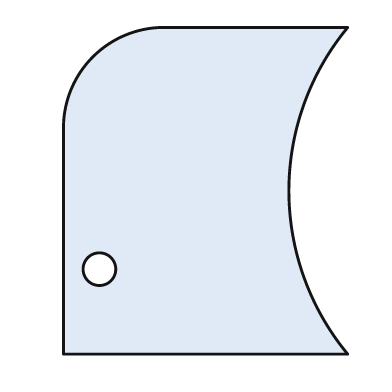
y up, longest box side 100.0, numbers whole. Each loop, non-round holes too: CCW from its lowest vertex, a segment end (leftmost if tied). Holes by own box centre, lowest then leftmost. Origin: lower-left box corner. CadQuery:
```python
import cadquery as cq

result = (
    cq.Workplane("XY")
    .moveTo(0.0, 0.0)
    .lineTo(87.0, 0.0)
    .threePointArc((69.0, 50.0), (87.0, 100.0))
    .lineTo(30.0, 100.0)
    .threePointArc((9.0, 91.0), (0.0, 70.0))
    .close()
    .moveTo(11.0, 26.0)
    .circle(5.0)
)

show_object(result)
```